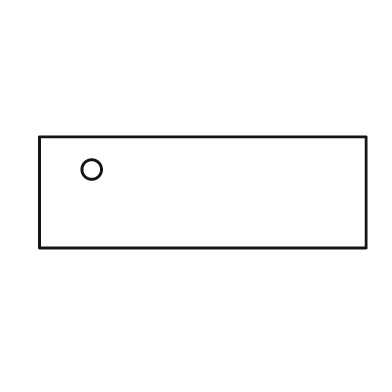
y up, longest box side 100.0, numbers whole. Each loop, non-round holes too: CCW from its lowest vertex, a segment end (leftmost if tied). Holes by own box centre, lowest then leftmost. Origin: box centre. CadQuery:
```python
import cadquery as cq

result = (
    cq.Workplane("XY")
    .moveTo(-50.0, -17.0)
    .lineTo(50.0, -17.0)
    .lineTo(50.0, 17.0)
    .lineTo(-50.0, 17.0)
    .close()
    .moveTo(-34.0, 7.0)
    .circle(3.0)
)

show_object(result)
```